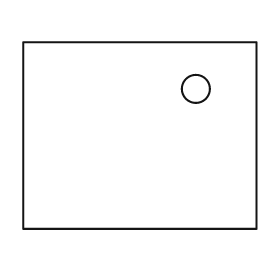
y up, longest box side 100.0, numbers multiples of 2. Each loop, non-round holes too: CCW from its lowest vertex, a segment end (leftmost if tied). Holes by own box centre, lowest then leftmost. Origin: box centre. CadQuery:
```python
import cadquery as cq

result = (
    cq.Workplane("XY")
    .moveTo(-50.0, -40.0)
    .lineTo(50.0, -40.0)
    .lineTo(50.0, 40.0)
    .lineTo(-50.0, 40.0)
    .close()
    .moveTo(24.0, 20.0)
    .circle(6.0)
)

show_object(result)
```